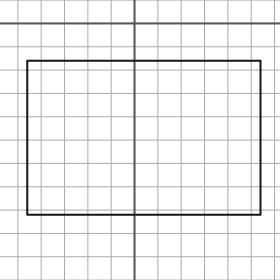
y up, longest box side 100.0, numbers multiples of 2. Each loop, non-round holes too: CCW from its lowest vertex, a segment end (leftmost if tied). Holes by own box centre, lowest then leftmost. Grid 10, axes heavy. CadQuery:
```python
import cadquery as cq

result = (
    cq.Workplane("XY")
    .moveTo(-46.0, -82.0)
    .lineTo(54.0, -82.0)
    .lineTo(54.0, -16.0)
    .lineTo(-46.0, -16.0)
    .close()
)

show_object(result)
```